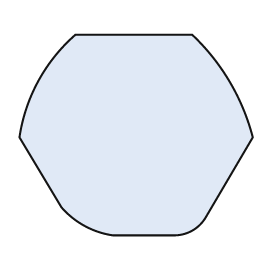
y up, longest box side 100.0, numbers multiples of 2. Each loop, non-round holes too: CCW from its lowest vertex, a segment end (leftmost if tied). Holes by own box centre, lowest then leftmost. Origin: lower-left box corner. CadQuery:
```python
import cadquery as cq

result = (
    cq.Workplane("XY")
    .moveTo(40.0, 0.0)
    .lineTo(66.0, 0.0)
    .threePointArc((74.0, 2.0), (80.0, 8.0))
    .lineTo(100.0, 42.0)
    .threePointArc((90.0, 66.0), (74.0, 86.0))
    .lineTo(24.0, 86.0)
    .threePointArc((8.0, 66.0), (0.0, 42.0))
    .lineTo(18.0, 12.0)
    .threePointArc((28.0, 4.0), (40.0, 0.0))
    .close()
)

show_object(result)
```